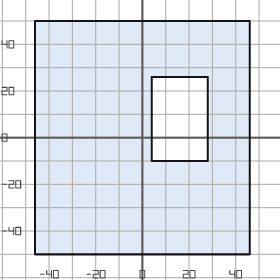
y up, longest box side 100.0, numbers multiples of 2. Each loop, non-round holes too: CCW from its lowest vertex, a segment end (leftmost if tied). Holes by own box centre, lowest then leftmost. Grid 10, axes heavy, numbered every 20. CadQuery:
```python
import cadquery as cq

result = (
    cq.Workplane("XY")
    .moveTo(-46.0, -50.0)
    .lineTo(46.0, -50.0)
    .lineTo(46.0, 50.0)
    .lineTo(-46.0, 50.0)
    .close()
    .moveTo(4.0, -10.0)
    .lineTo(28.0, -10.0)
    .lineTo(28.0, 26.0)
    .lineTo(4.0, 26.0)
    .close()
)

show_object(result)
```